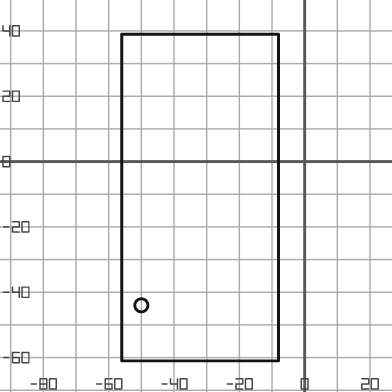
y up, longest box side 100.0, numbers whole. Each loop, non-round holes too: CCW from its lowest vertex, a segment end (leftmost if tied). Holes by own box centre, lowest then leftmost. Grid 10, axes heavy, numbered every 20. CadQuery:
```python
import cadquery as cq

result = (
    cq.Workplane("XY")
    .moveTo(-56.0, -61.0)
    .lineTo(-8.0, -61.0)
    .lineTo(-8.0, 39.0)
    .lineTo(-56.0, 39.0)
    .close()
    .moveTo(-50.0, -44.0)
    .circle(2.0)
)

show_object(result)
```